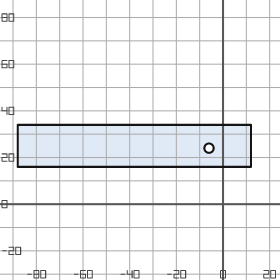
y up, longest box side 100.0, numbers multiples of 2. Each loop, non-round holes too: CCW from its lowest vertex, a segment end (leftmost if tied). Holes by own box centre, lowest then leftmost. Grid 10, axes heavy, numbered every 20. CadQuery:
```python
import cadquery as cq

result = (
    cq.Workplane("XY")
    .moveTo(-88.0, 16.0)
    .lineTo(12.0, 16.0)
    .lineTo(12.0, 34.0)
    .lineTo(-88.0, 34.0)
    .close()
    .moveTo(-6.0, 24.0)
    .circle(2.0)
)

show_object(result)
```